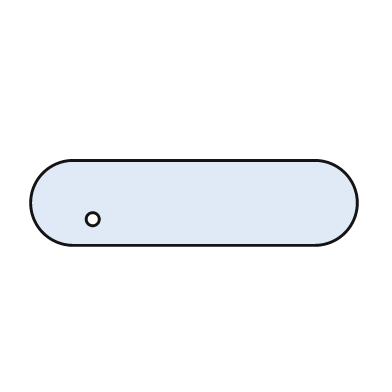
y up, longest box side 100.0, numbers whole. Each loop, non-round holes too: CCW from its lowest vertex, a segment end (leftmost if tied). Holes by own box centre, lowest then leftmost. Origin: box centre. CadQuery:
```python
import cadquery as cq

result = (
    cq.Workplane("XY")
    .moveTo(-37.0, -13.0)
    .lineTo(37.0, -13.0)
    .threePointArc((50.0, 0.0), (37.0, 13.0))
    .lineTo(-37.0, 13.0)
    .threePointArc((-50.0, 0.0), (-37.0, -13.0))
    .close()
    .moveTo(-31.0, -5.0)
    .circle(2.0)
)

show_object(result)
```